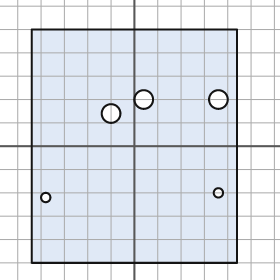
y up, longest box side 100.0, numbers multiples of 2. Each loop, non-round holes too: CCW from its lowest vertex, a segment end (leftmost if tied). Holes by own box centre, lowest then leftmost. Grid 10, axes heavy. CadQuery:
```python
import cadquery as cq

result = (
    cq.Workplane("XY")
    .moveTo(-44.0, -50.0)
    .lineTo(44.0, -50.0)
    .lineTo(44.0, 50.0)
    .lineTo(-44.0, 50.0)
    .close()
    .moveTo(-38.0, -22.0)
    .circle(2.0)
    .moveTo(36.0, -20.0)
    .circle(2.0)
    .moveTo(-10.0, 14.0)
    .circle(4.0)
    .moveTo(4.0, 20.0)
    .circle(4.0)
    .moveTo(36.0, 20.0)
    .circle(4.0)
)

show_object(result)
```